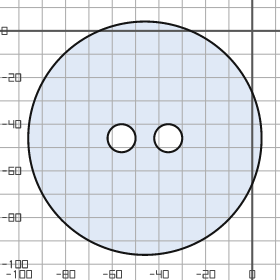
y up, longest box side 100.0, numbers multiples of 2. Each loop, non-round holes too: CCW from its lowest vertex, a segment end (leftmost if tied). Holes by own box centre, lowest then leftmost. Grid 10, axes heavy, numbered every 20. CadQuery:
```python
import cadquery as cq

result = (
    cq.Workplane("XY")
    .moveTo(-46.0, -46.0)
    .circle(50.0)
    .moveTo(-56.0, -46.0)
    .circle(6.0)
    .moveTo(-36.0, -46.0)
    .circle(6.0)
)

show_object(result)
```